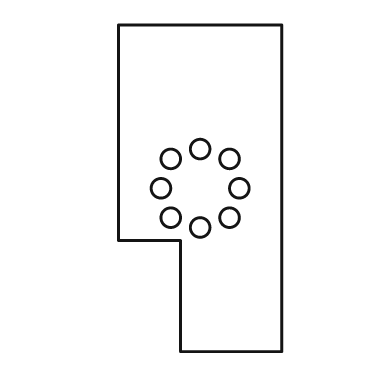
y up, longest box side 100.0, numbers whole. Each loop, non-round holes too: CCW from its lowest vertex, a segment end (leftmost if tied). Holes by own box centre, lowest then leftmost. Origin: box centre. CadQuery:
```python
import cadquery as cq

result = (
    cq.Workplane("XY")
    .moveTo(-6.0, -50.0)
    .lineTo(25.0, -50.0)
    .lineTo(25.0, 50.0)
    .lineTo(-25.0, 50.0)
    .lineTo(-25.0, -16.0)
    .lineTo(-6.0, -16.0)
    .close()
    .moveTo(0.0, -12.0)
    .circle(3.0)
    .moveTo(-9.0, -9.0)
    .circle(3.0)
    .moveTo(9.0, -9.0)
    .circle(3.0)
    .moveTo(-12.0, 0.0)
    .circle(3.0)
    .moveTo(12.0, 0.0)
    .circle(3.0)
    .moveTo(-9.0, 9.0)
    .circle(3.0)
    .moveTo(9.0, 9.0)
    .circle(3.0)
    .moveTo(0.0, 12.0)
    .circle(3.0)
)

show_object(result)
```